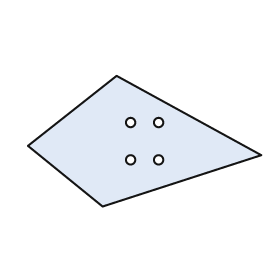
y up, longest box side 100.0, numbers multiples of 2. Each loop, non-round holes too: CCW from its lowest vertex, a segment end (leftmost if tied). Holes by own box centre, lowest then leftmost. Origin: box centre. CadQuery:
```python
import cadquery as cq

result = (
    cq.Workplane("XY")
    .moveTo(-18.0, -28.0)
    .lineTo(50.0, -6.0)
    .lineTo(-12.0, 28.0)
    .lineTo(-50.0, -2.0)
    .close()
    .moveTo(-6.0, -8.0)
    .circle(2.0)
    .moveTo(6.0, -8.0)
    .circle(2.0)
    .moveTo(-6.0, 8.0)
    .circle(2.0)
    .moveTo(6.0, 8.0)
    .circle(2.0)
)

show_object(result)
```